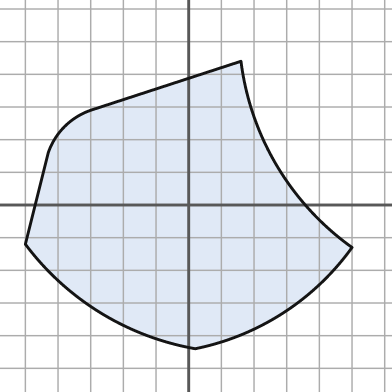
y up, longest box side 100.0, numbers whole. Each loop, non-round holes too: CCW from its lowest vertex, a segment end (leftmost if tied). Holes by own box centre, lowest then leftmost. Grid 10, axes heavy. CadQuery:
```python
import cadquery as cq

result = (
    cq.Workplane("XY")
    .moveTo(2.0, -44.0)
    .threePointArc((29.0, -33.0), (50.0, -13.0))
    .threePointArc((27.0, 12.0), (16.0, 44.0))
    .lineTo(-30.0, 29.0)
    .threePointArc((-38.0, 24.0), (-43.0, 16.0))
    .lineTo(-50.0, -12.0)
    .threePointArc((-27.0, -33.0), (2.0, -44.0))
    .close()
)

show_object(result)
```